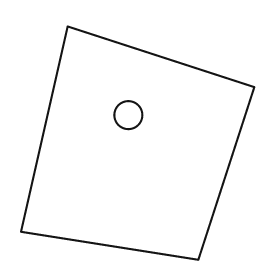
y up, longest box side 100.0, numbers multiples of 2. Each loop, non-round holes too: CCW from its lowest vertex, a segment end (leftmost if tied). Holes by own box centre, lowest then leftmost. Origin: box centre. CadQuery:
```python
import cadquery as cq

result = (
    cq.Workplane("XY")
    .moveTo(26.0, -50.0)
    .lineTo(50.0, 24.0)
    .lineTo(-30.0, 50.0)
    .lineTo(-50.0, -38.0)
    .close()
    .moveTo(-4.0, 12.0)
    .circle(6.0)
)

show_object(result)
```